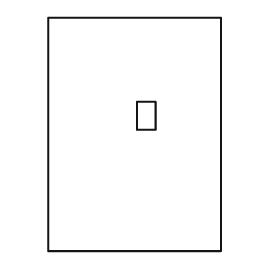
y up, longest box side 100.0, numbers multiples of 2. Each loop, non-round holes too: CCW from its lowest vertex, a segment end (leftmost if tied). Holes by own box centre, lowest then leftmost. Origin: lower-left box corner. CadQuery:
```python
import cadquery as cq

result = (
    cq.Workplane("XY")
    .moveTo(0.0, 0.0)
    .lineTo(74.0, 0.0)
    .lineTo(74.0, 100.0)
    .lineTo(0.0, 100.0)
    .close()
    .moveTo(38.0, 52.0)
    .lineTo(46.0, 52.0)
    .lineTo(46.0, 64.0)
    .lineTo(38.0, 64.0)
    .close()
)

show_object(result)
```